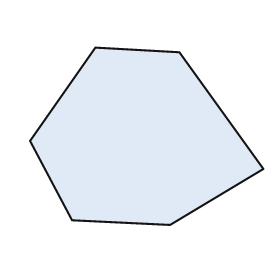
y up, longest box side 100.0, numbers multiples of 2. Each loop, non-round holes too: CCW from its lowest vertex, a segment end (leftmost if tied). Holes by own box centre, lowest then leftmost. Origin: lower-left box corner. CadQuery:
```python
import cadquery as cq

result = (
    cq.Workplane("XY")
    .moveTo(60.0, 0.0)
    .lineTo(100.0, 24.0)
    .lineTo(64.0, 74.0)
    .lineTo(28.0, 76.0)
    .lineTo(0.0, 36.0)
    .lineTo(18.0, 2.0)
    .close()
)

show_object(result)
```